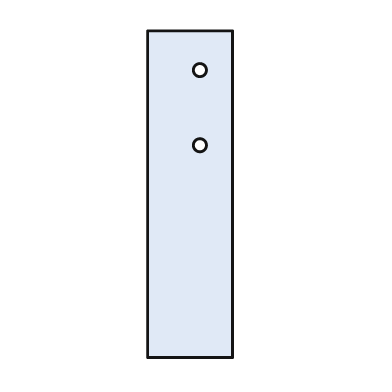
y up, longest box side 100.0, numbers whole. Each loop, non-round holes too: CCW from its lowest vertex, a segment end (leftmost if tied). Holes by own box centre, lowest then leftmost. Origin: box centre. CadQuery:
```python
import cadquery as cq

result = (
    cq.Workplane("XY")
    .moveTo(-13.0, -50.0)
    .lineTo(13.0, -50.0)
    .lineTo(13.0, 50.0)
    .lineTo(-13.0, 50.0)
    .close()
    .moveTo(3.0, 15.0)
    .circle(2.0)
    .moveTo(3.0, 38.0)
    .circle(2.0)
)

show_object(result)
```